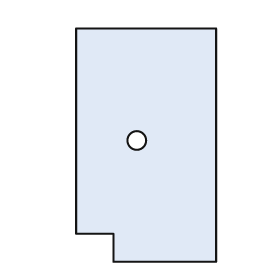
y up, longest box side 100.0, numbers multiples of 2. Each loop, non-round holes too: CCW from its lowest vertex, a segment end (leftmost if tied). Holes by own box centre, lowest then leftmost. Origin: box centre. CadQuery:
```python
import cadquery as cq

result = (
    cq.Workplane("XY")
    .moveTo(-14.0, -50.0)
    .lineTo(30.0, -50.0)
    .lineTo(30.0, 50.0)
    .lineTo(-30.0, 50.0)
    .lineTo(-30.0, -38.0)
    .lineTo(-14.0, -38.0)
    .close()
    .moveTo(-4.0, 2.0)
    .circle(4.0)
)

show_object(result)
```